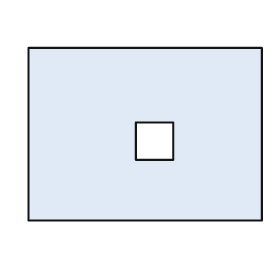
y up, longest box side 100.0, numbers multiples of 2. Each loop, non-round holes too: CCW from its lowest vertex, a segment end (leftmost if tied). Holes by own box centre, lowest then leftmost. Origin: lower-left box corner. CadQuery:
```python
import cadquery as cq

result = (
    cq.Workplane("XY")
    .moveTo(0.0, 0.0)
    .lineTo(100.0, 0.0)
    .lineTo(100.0, 74.0)
    .lineTo(0.0, 74.0)
    .close()
    .moveTo(46.0, 26.0)
    .lineTo(62.0, 26.0)
    .lineTo(62.0, 42.0)
    .lineTo(46.0, 42.0)
    .close()
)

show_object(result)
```